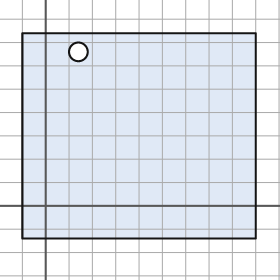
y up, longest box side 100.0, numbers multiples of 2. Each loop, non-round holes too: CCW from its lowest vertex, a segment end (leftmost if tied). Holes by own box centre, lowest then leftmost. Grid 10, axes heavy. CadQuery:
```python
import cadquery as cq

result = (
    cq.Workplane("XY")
    .moveTo(-10.0, -14.0)
    .lineTo(90.0, -14.0)
    .lineTo(90.0, 74.0)
    .lineTo(-10.0, 74.0)
    .close()
    .moveTo(14.0, 66.0)
    .circle(4.0)
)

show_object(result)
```